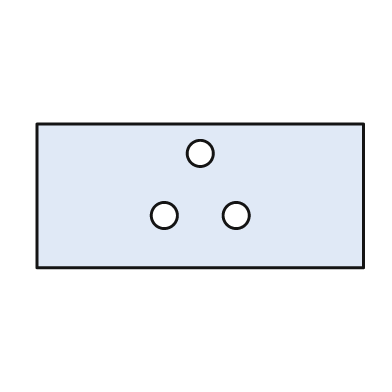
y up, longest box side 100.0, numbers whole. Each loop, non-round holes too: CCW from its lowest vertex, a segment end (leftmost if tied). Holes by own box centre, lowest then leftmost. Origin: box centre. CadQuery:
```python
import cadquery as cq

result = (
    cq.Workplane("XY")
    .moveTo(-50.0, -22.0)
    .lineTo(50.0, -22.0)
    .lineTo(50.0, 22.0)
    .lineTo(-50.0, 22.0)
    .close()
    .moveTo(-11.0, -6.0)
    .circle(4.0)
    .moveTo(11.0, -6.0)
    .circle(4.0)
    .moveTo(0.0, 13.0)
    .circle(4.0)
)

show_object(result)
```